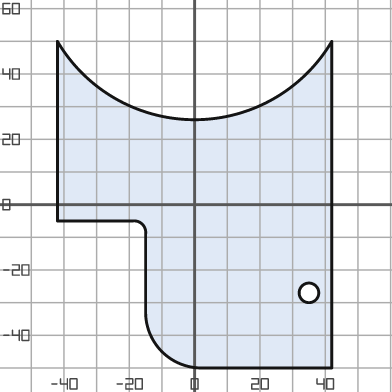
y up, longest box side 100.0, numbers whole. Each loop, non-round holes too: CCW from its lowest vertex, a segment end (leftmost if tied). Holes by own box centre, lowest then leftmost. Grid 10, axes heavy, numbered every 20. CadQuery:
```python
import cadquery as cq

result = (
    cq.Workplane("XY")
    .moveTo(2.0, -50.0)
    .lineTo(42.0, -50.0)
    .lineTo(42.0, 50.0)
    .threePointArc((0.0, 26.0), (-42.0, 50.0))
    .lineTo(-42.0, -5.0)
    .lineTo(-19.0, -5.0)
    .threePointArc((-16.0, -6.0), (-15.0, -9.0))
    .lineTo(-15.0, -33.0)
    .threePointArc((-10.0, -45.0), (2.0, -50.0))
    .close()
    .moveTo(35.0, -27.0)
    .circle(3.0)
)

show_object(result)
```